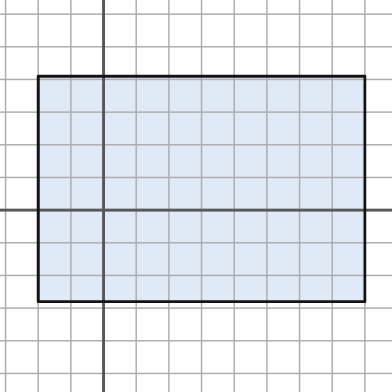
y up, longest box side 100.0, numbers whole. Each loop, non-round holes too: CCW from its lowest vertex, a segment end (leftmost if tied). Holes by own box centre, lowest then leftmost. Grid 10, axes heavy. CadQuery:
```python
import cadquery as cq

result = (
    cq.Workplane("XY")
    .moveTo(-20.0, -28.0)
    .lineTo(80.0, -28.0)
    .lineTo(80.0, 41.0)
    .lineTo(-20.0, 41.0)
    .close()
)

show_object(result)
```